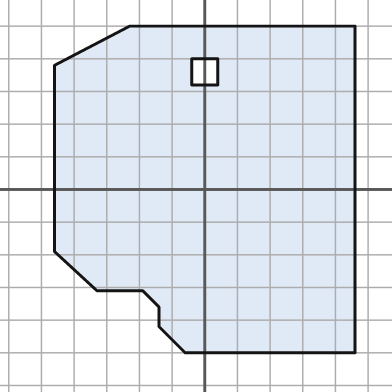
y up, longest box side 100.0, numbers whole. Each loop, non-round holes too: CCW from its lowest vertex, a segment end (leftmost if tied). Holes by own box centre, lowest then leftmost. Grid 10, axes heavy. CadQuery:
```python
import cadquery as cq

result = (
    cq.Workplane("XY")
    .moveTo(-6.0, -50.0)
    .lineTo(46.0, -50.0)
    .lineTo(46.0, 50.0)
    .lineTo(-23.0, 50.0)
    .lineTo(-46.0, 38.0)
    .lineTo(-46.0, -19.0)
    .lineTo(-33.0, -31.0)
    .lineTo(-19.0, -31.0)
    .lineTo(-14.0, -36.0)
    .lineTo(-14.0, -42.0)
    .close()
    .moveTo(-4.0, 32.0)
    .lineTo(4.0, 32.0)
    .lineTo(4.0, 40.0)
    .lineTo(-4.0, 40.0)
    .close()
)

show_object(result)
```